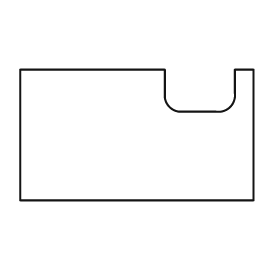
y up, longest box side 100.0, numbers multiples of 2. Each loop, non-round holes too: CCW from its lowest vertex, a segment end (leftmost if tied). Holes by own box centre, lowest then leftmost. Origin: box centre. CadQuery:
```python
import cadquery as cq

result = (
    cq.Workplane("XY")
    .moveTo(-50.0, -28.0)
    .lineTo(50.0, -28.0)
    .lineTo(50.0, 28.0)
    .lineTo(42.0, 28.0)
    .lineTo(42.0, 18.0)
    .threePointArc((40.0, 12.0), (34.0, 10.0))
    .lineTo(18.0, 10.0)
    .threePointArc((14.0, 12.0), (12.0, 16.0))
    .lineTo(12.0, 28.0)
    .lineTo(-50.0, 28.0)
    .close()
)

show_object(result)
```